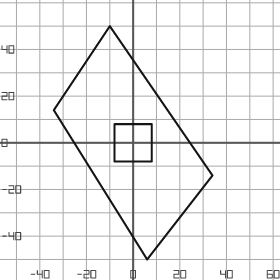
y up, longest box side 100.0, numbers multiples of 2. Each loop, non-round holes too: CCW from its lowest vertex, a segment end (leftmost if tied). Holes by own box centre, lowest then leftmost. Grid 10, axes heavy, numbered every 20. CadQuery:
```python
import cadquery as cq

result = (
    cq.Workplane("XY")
    .moveTo(6.0, -50.0)
    .lineTo(34.0, -14.0)
    .lineTo(-10.0, 50.0)
    .lineTo(-34.0, 14.0)
    .close()
    .moveTo(-8.0, -8.0)
    .lineTo(8.0, -8.0)
    .lineTo(8.0, 8.0)
    .lineTo(-8.0, 8.0)
    .close()
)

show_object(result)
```